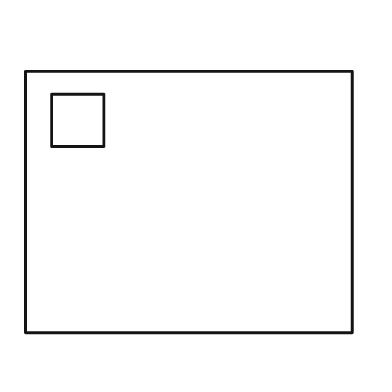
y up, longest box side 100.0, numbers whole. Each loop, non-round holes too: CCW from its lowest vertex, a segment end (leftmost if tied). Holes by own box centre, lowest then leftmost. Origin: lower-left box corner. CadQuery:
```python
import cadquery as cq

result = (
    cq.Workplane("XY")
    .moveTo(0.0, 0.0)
    .lineTo(100.0, 0.0)
    .lineTo(100.0, 80.0)
    .lineTo(0.0, 80.0)
    .close()
    .moveTo(8.0, 57.0)
    .lineTo(24.0, 57.0)
    .lineTo(24.0, 73.0)
    .lineTo(8.0, 73.0)
    .close()
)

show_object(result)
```